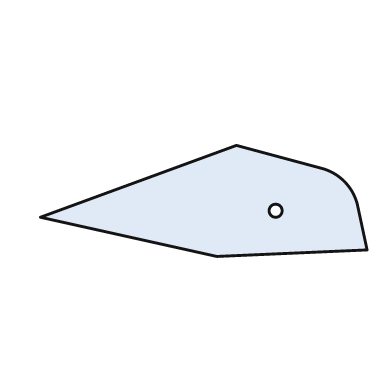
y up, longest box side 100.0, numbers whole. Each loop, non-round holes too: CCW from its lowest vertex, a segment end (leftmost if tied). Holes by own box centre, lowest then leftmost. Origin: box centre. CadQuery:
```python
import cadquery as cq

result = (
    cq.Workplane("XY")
    .moveTo(4.0, -17.0)
    .lineTo(50.0, -15.0)
    .lineTo(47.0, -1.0)
    .threePointArc((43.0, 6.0), (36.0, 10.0))
    .lineTo(10.0, 17.0)
    .lineTo(-50.0, -5.0)
    .close()
    .moveTo(22.0, -3.0)
    .circle(2.0)
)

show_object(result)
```